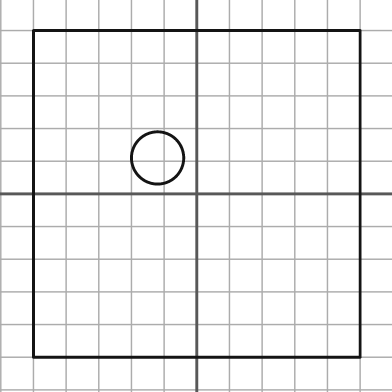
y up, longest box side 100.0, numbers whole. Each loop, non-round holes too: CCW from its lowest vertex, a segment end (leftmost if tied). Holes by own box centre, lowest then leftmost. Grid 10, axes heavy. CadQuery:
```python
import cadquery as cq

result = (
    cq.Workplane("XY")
    .moveTo(-50.0, -50.0)
    .lineTo(50.0, -50.0)
    .lineTo(50.0, 50.0)
    .lineTo(-50.0, 50.0)
    .close()
    .moveTo(-12.0, 11.0)
    .circle(8.0)
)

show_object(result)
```